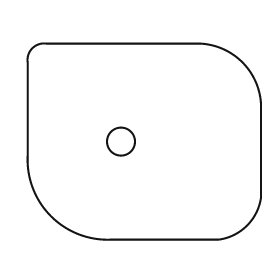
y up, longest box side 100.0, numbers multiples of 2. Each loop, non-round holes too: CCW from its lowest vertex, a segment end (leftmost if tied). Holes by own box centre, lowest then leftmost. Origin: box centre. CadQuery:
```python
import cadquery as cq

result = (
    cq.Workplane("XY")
    .moveTo(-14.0, -42.0)
    .lineTo(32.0, -42.0)
    .threePointArc((44.0, -36.0), (50.0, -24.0))
    .lineTo(50.0, 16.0)
    .threePointArc((42.0, 34.0), (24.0, 42.0))
    .lineTo(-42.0, 42.0)
    .threePointArc((-48.0, 40.0), (-50.0, 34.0))
    .lineTo(-50.0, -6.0)
    .threePointArc((-40.0, -32.0), (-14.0, -42.0))
    .close()
    .moveTo(-10.0, 0.0)
    .circle(6.0)
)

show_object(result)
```